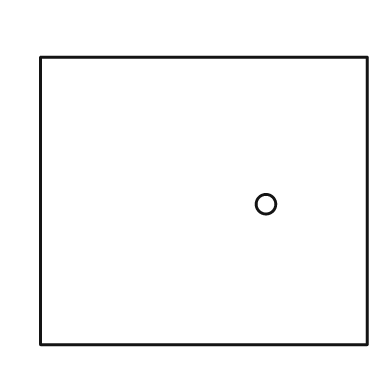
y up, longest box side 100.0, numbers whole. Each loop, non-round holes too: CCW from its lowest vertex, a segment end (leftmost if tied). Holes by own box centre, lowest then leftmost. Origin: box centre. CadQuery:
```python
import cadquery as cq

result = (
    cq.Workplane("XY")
    .moveTo(-50.0, -44.0)
    .lineTo(50.0, -44.0)
    .lineTo(50.0, 44.0)
    .lineTo(-50.0, 44.0)
    .close()
    .moveTo(19.0, -1.0)
    .circle(3.0)
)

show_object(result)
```